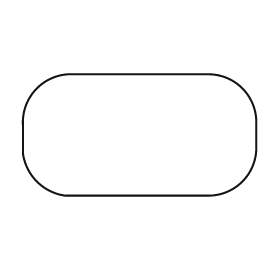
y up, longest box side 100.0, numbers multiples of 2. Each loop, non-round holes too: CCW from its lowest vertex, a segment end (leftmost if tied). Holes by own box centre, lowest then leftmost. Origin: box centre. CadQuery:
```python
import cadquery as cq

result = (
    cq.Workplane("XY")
    .moveTo(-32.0, -26.0)
    .lineTo(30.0, -26.0)
    .threePointArc((44.0, -20.0), (50.0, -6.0))
    .lineTo(50.0, 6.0)
    .threePointArc((44.0, 20.0), (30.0, 26.0))
    .lineTo(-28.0, 26.0)
    .threePointArc((-44.0, 20.0), (-50.0, 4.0))
    .lineTo(-50.0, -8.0)
    .threePointArc((-44.0, -20.0), (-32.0, -26.0))
    .close()
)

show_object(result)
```